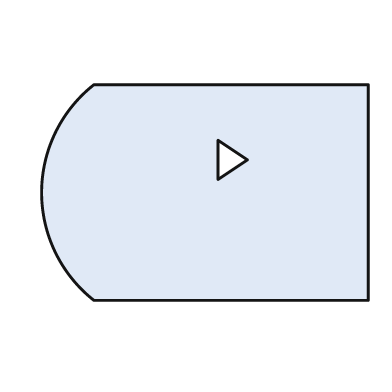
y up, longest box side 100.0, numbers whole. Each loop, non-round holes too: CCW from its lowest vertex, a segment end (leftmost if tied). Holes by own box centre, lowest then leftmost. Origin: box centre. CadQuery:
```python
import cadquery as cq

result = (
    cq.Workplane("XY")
    .moveTo(-34.0, -33.0)
    .lineTo(50.0, -33.0)
    .lineTo(50.0, 33.0)
    .lineTo(-34.0, 33.0)
    .threePointArc((-50.0, 0.0), (-34.0, -33.0))
    .close()
    .moveTo(4.0, 4.0)
    .lineTo(13.0, 10.0)
    .lineTo(4.0, 16.0)
    .close()
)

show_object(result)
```